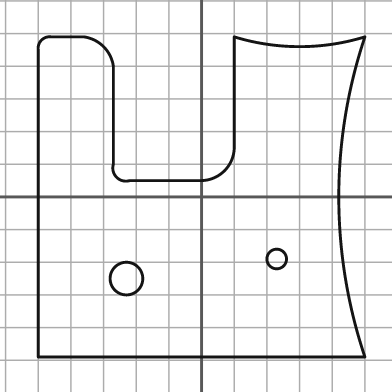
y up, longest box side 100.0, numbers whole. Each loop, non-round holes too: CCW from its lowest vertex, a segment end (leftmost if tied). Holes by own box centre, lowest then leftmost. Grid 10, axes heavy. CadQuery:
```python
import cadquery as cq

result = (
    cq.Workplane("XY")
    .moveTo(-50.0, -49.0)
    .lineTo(50.0, -49.0)
    .threePointArc((42.0, 0.0), (50.0, 49.0))
    .threePointArc((30.0, 46.0), (10.0, 49.0))
    .lineTo(10.0, 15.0)
    .threePointArc((7.0, 8.0), (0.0, 5.0))
    .lineTo(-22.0, 5.0)
    .threePointArc((-26.0, 6.0), (-27.0, 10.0))
    .lineTo(-27.0, 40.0)
    .threePointArc((-30.0, 46.0), (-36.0, 49.0))
    .lineTo(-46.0, 49.0)
    .threePointArc((-49.0, 48.0), (-50.0, 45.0))
    .close()
    .moveTo(-23.0, -25.0)
    .circle(5.0)
    .moveTo(23.0, -19.0)
    .circle(3.0)
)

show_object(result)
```